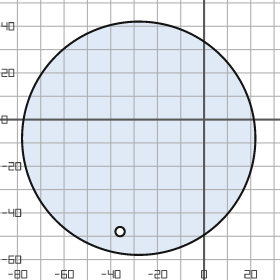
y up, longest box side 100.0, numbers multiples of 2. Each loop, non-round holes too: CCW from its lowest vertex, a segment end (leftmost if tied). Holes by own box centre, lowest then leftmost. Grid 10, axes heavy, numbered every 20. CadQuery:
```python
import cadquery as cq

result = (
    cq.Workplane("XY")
    .moveTo(-28.0, -8.0)
    .circle(50.0)
    .moveTo(-36.0, -48.0)
    .circle(2.0)
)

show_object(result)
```